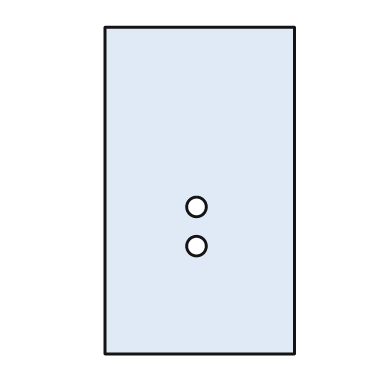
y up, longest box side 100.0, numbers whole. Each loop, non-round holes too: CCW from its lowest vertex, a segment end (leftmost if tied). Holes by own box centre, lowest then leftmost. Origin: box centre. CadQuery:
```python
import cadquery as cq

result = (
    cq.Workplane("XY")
    .moveTo(-29.0, -50.0)
    .lineTo(29.0, -50.0)
    .lineTo(29.0, 50.0)
    .lineTo(-29.0, 50.0)
    .close()
    .moveTo(-1.0, -17.0)
    .circle(3.0)
    .moveTo(-1.0, -5.0)
    .circle(3.0)
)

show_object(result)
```